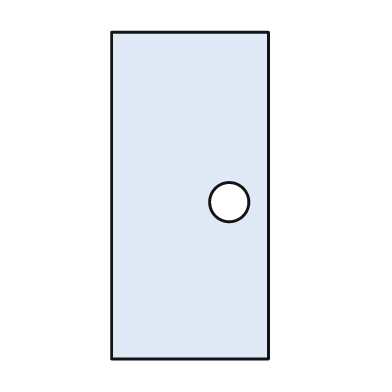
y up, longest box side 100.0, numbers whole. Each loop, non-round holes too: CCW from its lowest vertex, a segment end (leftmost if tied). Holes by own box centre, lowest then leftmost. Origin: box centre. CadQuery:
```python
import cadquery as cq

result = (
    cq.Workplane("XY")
    .moveTo(-24.0, -50.0)
    .lineTo(24.0, -50.0)
    .lineTo(24.0, 50.0)
    .lineTo(-24.0, 50.0)
    .close()
    .moveTo(12.0, -2.0)
    .circle(6.0)
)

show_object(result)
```